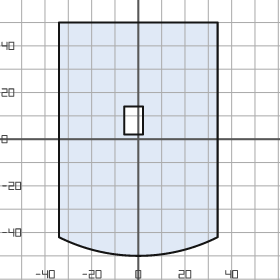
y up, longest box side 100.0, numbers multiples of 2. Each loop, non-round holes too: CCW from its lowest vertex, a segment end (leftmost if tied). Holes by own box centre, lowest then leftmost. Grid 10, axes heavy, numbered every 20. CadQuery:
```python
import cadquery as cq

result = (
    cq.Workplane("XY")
    .moveTo(-34.0, -42.0)
    .threePointArc((0.0, -50.0), (34.0, -42.0))
    .lineTo(34.0, 50.0)
    .lineTo(-34.0, 50.0)
    .close()
    .moveTo(-6.0, 2.0)
    .lineTo(2.0, 2.0)
    .lineTo(2.0, 14.0)
    .lineTo(-6.0, 14.0)
    .close()
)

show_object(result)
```